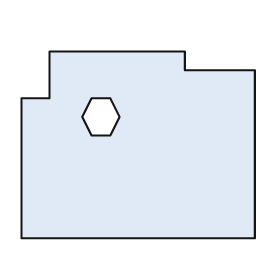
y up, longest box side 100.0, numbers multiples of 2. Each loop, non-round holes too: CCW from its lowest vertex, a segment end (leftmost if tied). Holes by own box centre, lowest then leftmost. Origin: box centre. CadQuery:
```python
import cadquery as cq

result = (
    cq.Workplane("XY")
    .moveTo(-50.0, -40.0)
    .lineTo(50.0, -40.0)
    .lineTo(50.0, 32.0)
    .lineTo(20.0, 32.0)
    .lineTo(20.0, 40.0)
    .lineTo(-38.0, 40.0)
    .lineTo(-38.0, 20.0)
    .lineTo(-50.0, 20.0)
    .close()
    .moveTo(-20.0, 4.0)
    .lineTo(-12.0, 4.0)
    .lineTo(-8.0, 12.0)
    .lineTo(-12.0, 20.0)
    .lineTo(-20.0, 20.0)
    .lineTo(-24.0, 12.0)
    .close()
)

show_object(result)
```